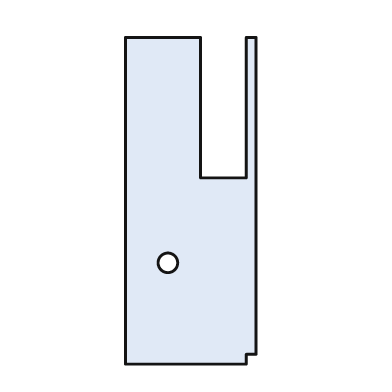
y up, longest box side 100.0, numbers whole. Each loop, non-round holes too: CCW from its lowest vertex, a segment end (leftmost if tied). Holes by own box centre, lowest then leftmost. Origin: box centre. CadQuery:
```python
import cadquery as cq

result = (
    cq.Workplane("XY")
    .moveTo(-20.0, -50.0)
    .lineTo(17.0, -50.0)
    .lineTo(17.0, -47.0)
    .lineTo(20.0, -47.0)
    .lineTo(20.0, 50.0)
    .lineTo(17.0, 50.0)
    .lineTo(17.0, 7.0)
    .lineTo(3.0, 7.0)
    .lineTo(3.0, 50.0)
    .lineTo(-20.0, 50.0)
    .close()
    .moveTo(-7.0, -19.0)
    .circle(3.0)
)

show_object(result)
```